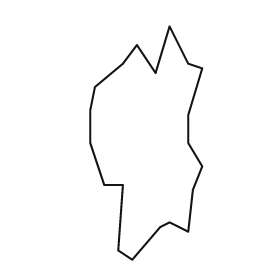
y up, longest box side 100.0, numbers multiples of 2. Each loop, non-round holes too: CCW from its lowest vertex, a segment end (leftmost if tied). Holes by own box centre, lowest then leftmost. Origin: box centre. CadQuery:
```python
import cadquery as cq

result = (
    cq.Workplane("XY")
    .moveTo(-6.0, -50.0)
    .lineTo(6.0, -36.0)
    .lineTo(10.0, -34.0)
    .lineTo(18.0, -38.0)
    .lineTo(20.0, -20.0)
    .lineTo(24.0, -10.0)
    .lineTo(18.0, 0.0)
    .lineTo(18.0, 12.0)
    .lineTo(24.0, 32.0)
    .lineTo(18.0, 34.0)
    .lineTo(10.0, 50.0)
    .lineTo(4.0, 30.0)
    .lineTo(-4.0, 42.0)
    .lineTo(-10.0, 34.0)
    .lineTo(-22.0, 24.0)
    .lineTo(-24.0, 14.0)
    .lineTo(-24.0, 0.0)
    .lineTo(-18.0, -18.0)
    .lineTo(-10.0, -18.0)
    .lineTo(-12.0, -46.0)
    .close()
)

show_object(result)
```